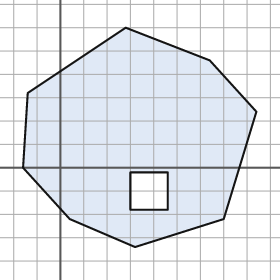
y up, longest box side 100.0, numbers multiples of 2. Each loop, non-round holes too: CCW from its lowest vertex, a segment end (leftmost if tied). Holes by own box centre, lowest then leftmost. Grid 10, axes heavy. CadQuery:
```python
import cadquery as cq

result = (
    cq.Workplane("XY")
    .moveTo(32.0, -34.0)
    .lineTo(70.0, -22.0)
    .lineTo(84.0, 24.0)
    .lineTo(64.0, 46.0)
    .lineTo(28.0, 60.0)
    .lineTo(-14.0, 32.0)
    .lineTo(-16.0, 0.0)
    .lineTo(4.0, -22.0)
    .close()
    .moveTo(30.0, -18.0)
    .lineTo(46.0, -18.0)
    .lineTo(46.0, -2.0)
    .lineTo(30.0, -2.0)
    .close()
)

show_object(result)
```